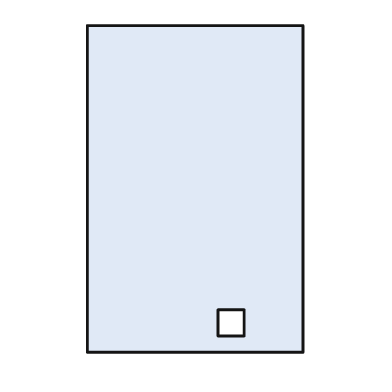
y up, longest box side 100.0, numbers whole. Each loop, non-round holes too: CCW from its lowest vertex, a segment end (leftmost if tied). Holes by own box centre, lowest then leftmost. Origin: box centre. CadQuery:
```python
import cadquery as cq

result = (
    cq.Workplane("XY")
    .moveTo(-33.0, -50.0)
    .lineTo(33.0, -50.0)
    .lineTo(33.0, 50.0)
    .lineTo(-33.0, 50.0)
    .close()
    .moveTo(7.0, -45.0)
    .lineTo(15.0, -45.0)
    .lineTo(15.0, -37.0)
    .lineTo(7.0, -37.0)
    .close()
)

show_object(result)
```